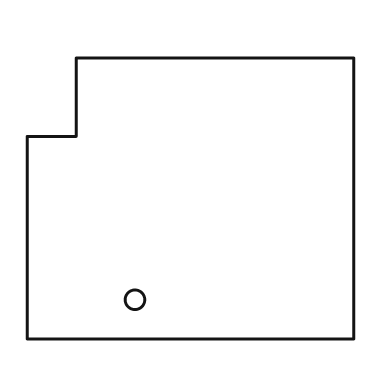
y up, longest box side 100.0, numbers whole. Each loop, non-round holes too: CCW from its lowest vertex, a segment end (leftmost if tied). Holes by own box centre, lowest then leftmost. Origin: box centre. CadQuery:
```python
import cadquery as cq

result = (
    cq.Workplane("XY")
    .moveTo(-50.0, -43.0)
    .lineTo(50.0, -43.0)
    .lineTo(50.0, 43.0)
    .lineTo(-35.0, 43.0)
    .lineTo(-35.0, 19.0)
    .lineTo(-50.0, 19.0)
    .close()
    .moveTo(-17.0, -31.0)
    .circle(3.0)
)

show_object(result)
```